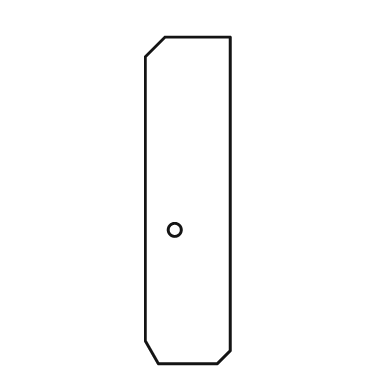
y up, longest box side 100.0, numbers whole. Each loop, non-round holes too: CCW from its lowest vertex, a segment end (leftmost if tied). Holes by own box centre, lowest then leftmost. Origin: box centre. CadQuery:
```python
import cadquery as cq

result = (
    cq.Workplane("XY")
    .moveTo(-9.0, -50.0)
    .lineTo(9.0, -50.0)
    .lineTo(13.0, -46.0)
    .lineTo(13.0, 50.0)
    .lineTo(-7.0, 50.0)
    .lineTo(-13.0, 44.0)
    .lineTo(-13.0, -43.0)
    .close()
    .moveTo(-4.0, -9.0)
    .circle(2.0)
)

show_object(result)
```